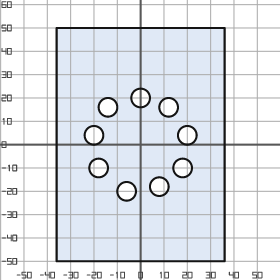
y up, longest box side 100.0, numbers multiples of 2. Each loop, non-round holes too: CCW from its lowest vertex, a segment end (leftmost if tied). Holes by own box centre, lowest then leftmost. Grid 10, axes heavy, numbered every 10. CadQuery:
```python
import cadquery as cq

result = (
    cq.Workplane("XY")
    .moveTo(-36.0, -50.0)
    .lineTo(36.0, -50.0)
    .lineTo(36.0, 50.0)
    .lineTo(-36.0, 50.0)
    .close()
    .moveTo(-6.0, -20.0)
    .circle(4.0)
    .moveTo(8.0, -18.0)
    .circle(4.0)
    .moveTo(-18.0, -10.0)
    .circle(4.0)
    .moveTo(18.0, -10.0)
    .circle(4.0)
    .moveTo(-20.0, 4.0)
    .circle(4.0)
    .moveTo(20.0, 4.0)
    .circle(4.0)
    .moveTo(-14.0, 16.0)
    .circle(4.0)
    .moveTo(12.0, 16.0)
    .circle(4.0)
    .moveTo(0.0, 20.0)
    .circle(4.0)
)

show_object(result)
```